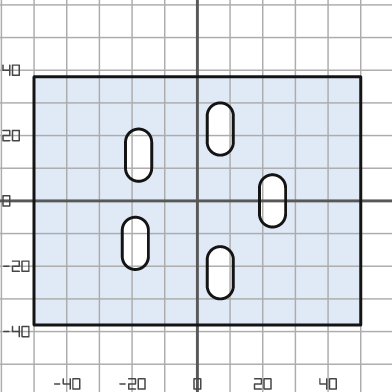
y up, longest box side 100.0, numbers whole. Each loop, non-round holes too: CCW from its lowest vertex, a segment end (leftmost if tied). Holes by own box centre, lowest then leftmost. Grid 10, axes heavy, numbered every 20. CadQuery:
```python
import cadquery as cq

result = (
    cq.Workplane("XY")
    .moveTo(-50.0, -38.0)
    .lineTo(50.0, -38.0)
    .lineTo(50.0, 38.0)
    .lineTo(-50.0, 38.0)
    .close()
    .moveTo(3.0, -26.0)
    .threePointArc((7.0, -30.0), (11.0, -26.0))
    .lineTo(11.0, -18.0)
    .threePointArc((7.0, -14.0), (3.0, -18.0))
    .close()
    .moveTo(-23.0, -17.0)
    .threePointArc((-19.0, -21.0), (-15.0, -17.0))
    .lineTo(-15.0, -9.0)
    .threePointArc((-19.0, -5.0), (-23.0, -9.0))
    .close()
    .moveTo(19.0, -4.0)
    .threePointArc((23.0, -8.0), (27.0, -4.0))
    .lineTo(27.0, 4.0)
    .threePointArc((23.0, 8.0), (19.0, 4.0))
    .close()
    .moveTo(-22.0, 10.0)
    .threePointArc((-18.0, 6.0), (-14.0, 10.0))
    .lineTo(-14.0, 18.0)
    .threePointArc((-18.0, 22.0), (-22.0, 18.0))
    .close()
    .moveTo(3.0, 18.0)
    .threePointArc((7.0, 14.0), (11.0, 18.0))
    .lineTo(11.0, 26.0)
    .threePointArc((7.0, 30.0), (3.0, 26.0))
    .close()
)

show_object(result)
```